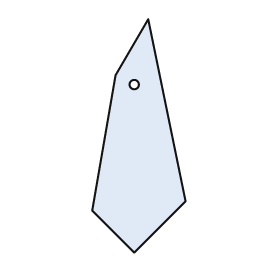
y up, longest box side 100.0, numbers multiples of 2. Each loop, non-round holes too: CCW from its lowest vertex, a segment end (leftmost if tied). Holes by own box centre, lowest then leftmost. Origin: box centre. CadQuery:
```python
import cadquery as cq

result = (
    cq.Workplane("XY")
    .moveTo(-2.0, -50.0)
    .lineTo(20.0, -28.0)
    .lineTo(4.0, 50.0)
    .lineTo(-10.0, 26.0)
    .lineTo(-20.0, -32.0)
    .close()
    .moveTo(-2.0, 22.0)
    .circle(2.0)
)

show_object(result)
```